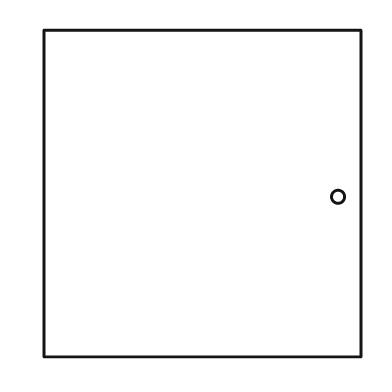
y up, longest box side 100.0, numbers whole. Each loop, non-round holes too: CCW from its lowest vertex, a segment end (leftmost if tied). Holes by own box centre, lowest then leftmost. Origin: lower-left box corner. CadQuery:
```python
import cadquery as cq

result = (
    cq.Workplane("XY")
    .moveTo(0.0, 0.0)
    .lineTo(97.0, 0.0)
    .lineTo(97.0, 100.0)
    .lineTo(0.0, 100.0)
    .close()
    .moveTo(90.0, 49.0)
    .circle(2.0)
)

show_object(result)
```